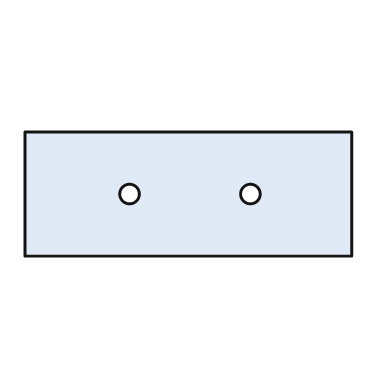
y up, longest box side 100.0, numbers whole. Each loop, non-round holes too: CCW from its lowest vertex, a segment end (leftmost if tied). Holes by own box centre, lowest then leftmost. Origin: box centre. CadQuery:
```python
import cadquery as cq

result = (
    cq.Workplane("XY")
    .moveTo(-50.0, -19.0)
    .lineTo(50.0, -19.0)
    .lineTo(50.0, 19.0)
    .lineTo(-50.0, 19.0)
    .close()
    .moveTo(-18.0, 0.0)
    .circle(3.0)
    .moveTo(19.0, 0.0)
    .circle(3.0)
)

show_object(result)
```